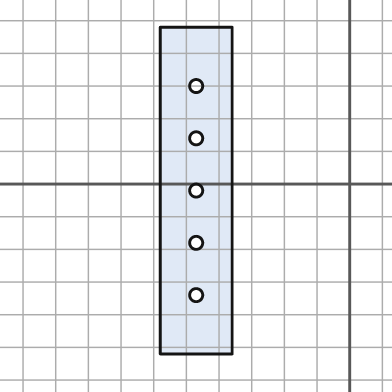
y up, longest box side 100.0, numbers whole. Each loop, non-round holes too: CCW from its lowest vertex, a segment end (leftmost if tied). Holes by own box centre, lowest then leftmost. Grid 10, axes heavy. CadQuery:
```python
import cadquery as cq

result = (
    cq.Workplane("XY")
    .moveTo(-58.0, -52.0)
    .lineTo(-36.0, -52.0)
    .lineTo(-36.0, 48.0)
    .lineTo(-58.0, 48.0)
    .close()
    .moveTo(-47.0, -34.0)
    .circle(2.0)
    .moveTo(-47.0, -18.0)
    .circle(2.0)
    .moveTo(-47.0, -2.0)
    .circle(2.0)
    .moveTo(-47.0, 14.0)
    .circle(2.0)
    .moveTo(-47.0, 30.0)
    .circle(2.0)
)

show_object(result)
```